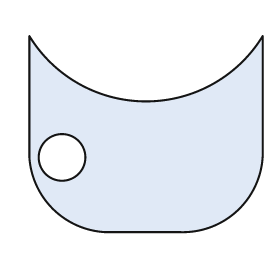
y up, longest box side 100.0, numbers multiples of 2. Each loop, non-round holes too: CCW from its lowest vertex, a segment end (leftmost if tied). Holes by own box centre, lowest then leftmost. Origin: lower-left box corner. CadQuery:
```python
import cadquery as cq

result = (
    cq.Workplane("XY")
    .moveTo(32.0, 0.0)
    .lineTo(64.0, 0.0)
    .threePointArc((90.0, 10.0), (100.0, 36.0))
    .lineTo(100.0, 84.0)
    .threePointArc((50.0, 56.0), (0.0, 84.0))
    .lineTo(0.0, 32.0)
    .threePointArc((10.0, 10.0), (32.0, 0.0))
    .close()
    .moveTo(14.0, 32.0)
    .circle(10.0)
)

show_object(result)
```